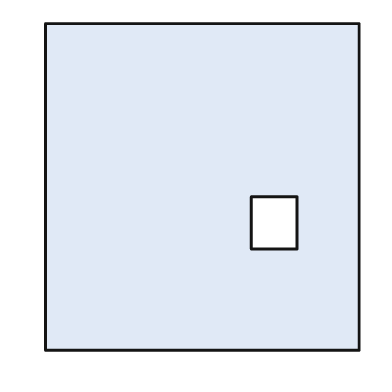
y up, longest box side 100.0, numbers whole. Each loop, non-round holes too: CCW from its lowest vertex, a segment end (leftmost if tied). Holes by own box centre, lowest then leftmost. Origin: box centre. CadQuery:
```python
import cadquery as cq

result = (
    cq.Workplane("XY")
    .moveTo(-48.0, -50.0)
    .lineTo(48.0, -50.0)
    .lineTo(48.0, 50.0)
    .lineTo(-48.0, 50.0)
    .close()
    .moveTo(15.0, -19.0)
    .lineTo(29.0, -19.0)
    .lineTo(29.0, -3.0)
    .lineTo(15.0, -3.0)
    .close()
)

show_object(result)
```